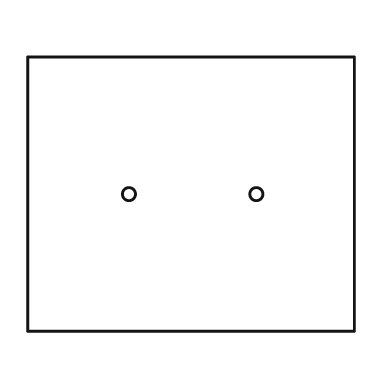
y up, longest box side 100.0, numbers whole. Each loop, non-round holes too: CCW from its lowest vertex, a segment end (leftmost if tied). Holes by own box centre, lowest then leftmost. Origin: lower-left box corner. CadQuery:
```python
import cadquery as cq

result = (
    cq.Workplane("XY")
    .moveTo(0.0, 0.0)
    .lineTo(100.0, 0.0)
    .lineTo(100.0, 84.0)
    .lineTo(0.0, 84.0)
    .close()
    .moveTo(31.0, 42.0)
    .circle(2.0)
    .moveTo(70.0, 42.0)
    .circle(2.0)
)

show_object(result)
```